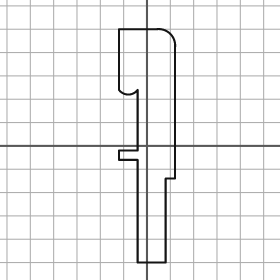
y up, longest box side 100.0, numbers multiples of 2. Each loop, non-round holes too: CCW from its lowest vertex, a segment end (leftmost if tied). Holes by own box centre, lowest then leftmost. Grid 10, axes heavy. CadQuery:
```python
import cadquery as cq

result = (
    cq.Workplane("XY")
    .moveTo(-4.0, -50.0)
    .lineTo(8.0, -50.0)
    .lineTo(8.0, -14.0)
    .lineTo(12.0, -14.0)
    .lineTo(12.0, 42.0)
    .threePointArc((10.0, 48.0), (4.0, 50.0))
    .lineTo(-12.0, 50.0)
    .lineTo(-12.0, 24.0)
    .threePointArc((-8.0, 22.0), (-4.0, 24.0))
    .lineTo(-4.0, -2.0)
    .lineTo(-12.0, -2.0)
    .lineTo(-12.0, -6.0)
    .lineTo(-4.0, -6.0)
    .close()
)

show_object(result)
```